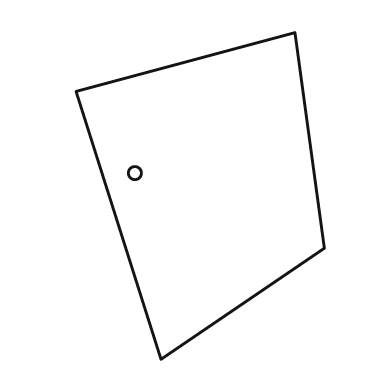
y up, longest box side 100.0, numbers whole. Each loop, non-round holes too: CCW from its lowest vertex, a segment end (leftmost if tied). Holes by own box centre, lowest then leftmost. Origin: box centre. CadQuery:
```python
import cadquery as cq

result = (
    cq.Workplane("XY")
    .moveTo(-12.0, -50.0)
    .lineTo(38.0, -16.0)
    .lineTo(29.0, 50.0)
    .lineTo(-38.0, 32.0)
    .close()
    .moveTo(-20.0, 7.0)
    .circle(2.0)
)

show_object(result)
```